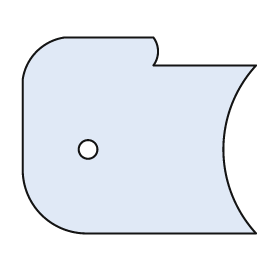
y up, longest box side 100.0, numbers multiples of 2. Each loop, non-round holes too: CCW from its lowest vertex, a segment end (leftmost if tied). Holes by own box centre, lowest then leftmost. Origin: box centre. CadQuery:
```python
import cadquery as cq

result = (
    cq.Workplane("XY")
    .moveTo(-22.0, -42.0)
    .lineTo(50.0, -42.0)
    .threePointArc((36.0, -6.0), (50.0, 30.0))
    .lineTo(6.0, 30.0)
    .threePointArc((8.0, 36.0), (6.0, 42.0))
    .lineTo(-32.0, 42.0)
    .threePointArc((-44.0, 36.0), (-50.0, 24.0))
    .lineTo(-50.0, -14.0)
    .threePointArc((-42.0, -34.0), (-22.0, -42.0))
    .close()
    .moveTo(-22.0, -6.0)
    .circle(4.0)
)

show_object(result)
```